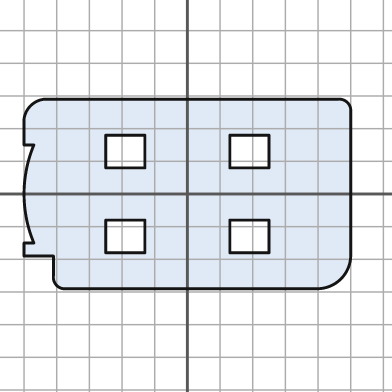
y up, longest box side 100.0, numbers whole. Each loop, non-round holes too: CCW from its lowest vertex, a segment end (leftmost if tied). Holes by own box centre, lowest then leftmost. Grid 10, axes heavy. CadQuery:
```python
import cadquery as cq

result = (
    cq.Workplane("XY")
    .moveTo(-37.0, -29.0)
    .lineTo(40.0, -29.0)
    .threePointArc((47.0, -26.0), (50.0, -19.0))
    .lineTo(50.0, 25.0)
    .threePointArc((49.0, 28.0), (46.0, 29.0))
    .lineTo(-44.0, 29.0)
    .threePointArc((-48.0, 27.0), (-50.0, 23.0))
    .lineTo(-50.0, 15.0)
    .lineTo(-47.0, 15.0)
    .threePointArc((-50.0, 0.0), (-47.0, -15.0))
    .lineTo(-50.0, -15.0)
    .lineTo(-50.0, -19.0)
    .lineTo(-41.0, -19.0)
    .lineTo(-41.0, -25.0)
    .threePointArc((-40.0, -28.0), (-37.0, -29.0))
    .close()
    .moveTo(-25.0, -18.0)
    .lineTo(-13.0, -18.0)
    .lineTo(-13.0, -8.0)
    .lineTo(-25.0, -8.0)
    .close()
    .moveTo(13.0, -18.0)
    .lineTo(25.0, -18.0)
    .lineTo(25.0, -8.0)
    .lineTo(13.0, -8.0)
    .close()
    .moveTo(-25.0, 8.0)
    .lineTo(-13.0, 8.0)
    .lineTo(-13.0, 18.0)
    .lineTo(-25.0, 18.0)
    .close()
    .moveTo(13.0, 8.0)
    .lineTo(25.0, 8.0)
    .lineTo(25.0, 18.0)
    .lineTo(13.0, 18.0)
    .close()
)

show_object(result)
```